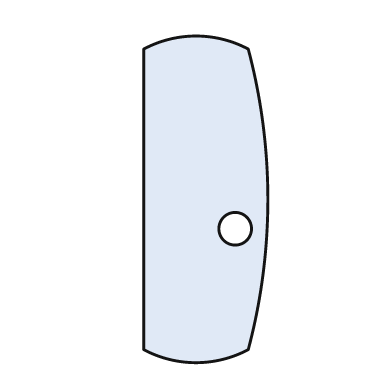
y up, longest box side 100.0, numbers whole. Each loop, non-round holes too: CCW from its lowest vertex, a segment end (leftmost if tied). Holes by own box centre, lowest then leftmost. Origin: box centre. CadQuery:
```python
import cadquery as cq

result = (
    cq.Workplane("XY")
    .moveTo(-19.0, -46.0)
    .threePointArc((-3.0, -50.0), (13.0, -46.0))
    .threePointArc((19.0, 0.0), (13.0, 46.0))
    .threePointArc((-3.0, 50.0), (-19.0, 46.0))
    .close()
    .moveTo(9.0, -9.0)
    .circle(5.0)
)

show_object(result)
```